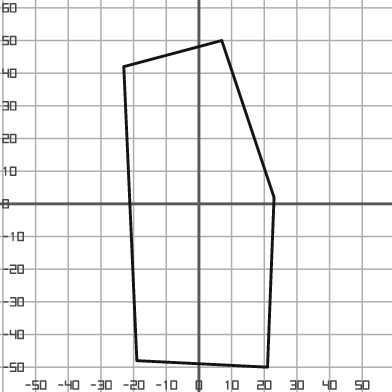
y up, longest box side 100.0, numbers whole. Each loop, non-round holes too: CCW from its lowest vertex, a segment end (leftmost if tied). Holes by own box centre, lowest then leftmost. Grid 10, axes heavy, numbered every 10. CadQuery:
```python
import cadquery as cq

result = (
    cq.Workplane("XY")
    .moveTo(21.0, -50.0)
    .lineTo(23.0, 2.0)
    .lineTo(7.0, 50.0)
    .lineTo(-23.0, 42.0)
    .lineTo(-19.0, -48.0)
    .close()
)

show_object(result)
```